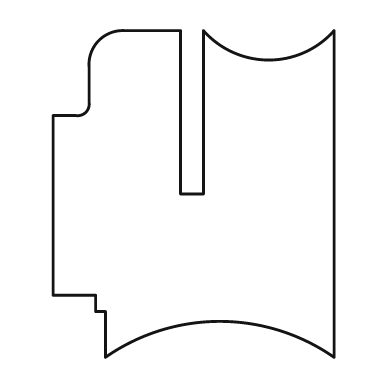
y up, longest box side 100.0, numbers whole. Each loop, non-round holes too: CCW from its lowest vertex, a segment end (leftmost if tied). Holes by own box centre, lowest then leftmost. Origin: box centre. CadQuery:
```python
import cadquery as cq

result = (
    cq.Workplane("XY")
    .moveTo(-27.0, -50.0)
    .threePointArc((8.0, -39.0), (43.0, -50.0))
    .lineTo(43.0, 50.0)
    .threePointArc((23.0, 41.0), (3.0, 50.0))
    .lineTo(3.0, 0.0)
    .lineTo(-4.0, 0.0)
    .lineTo(-4.0, 50.0)
    .lineTo(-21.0, 50.0)
    .threePointArc((-29.0, 47.0), (-32.0, 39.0))
    .lineTo(-32.0, 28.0)
    .threePointArc((-33.0, 25.0), (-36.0, 24.0))
    .lineTo(-43.0, 24.0)
    .lineTo(-43.0, -31.0)
    .lineTo(-30.0, -31.0)
    .lineTo(-30.0, -36.0)
    .lineTo(-27.0, -36.0)
    .close()
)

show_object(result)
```